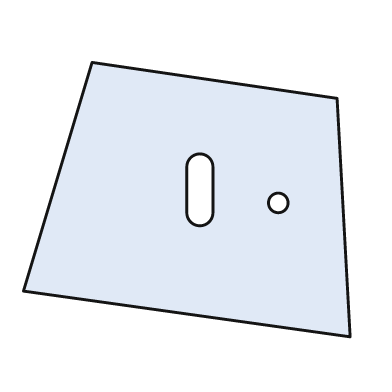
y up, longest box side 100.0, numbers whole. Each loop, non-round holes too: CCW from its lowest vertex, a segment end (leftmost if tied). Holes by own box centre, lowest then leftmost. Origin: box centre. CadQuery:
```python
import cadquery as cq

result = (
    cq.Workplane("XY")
    .moveTo(50.0, -42.0)
    .lineTo(46.0, 31.0)
    .lineTo(-29.0, 42.0)
    .lineTo(-50.0, -28.0)
    .close()
    .moveTo(28.0, -1.0)
    .circle(3.0)
    .moveTo(0.0, -4.0)
    .threePointArc((4.0, -8.0), (8.0, -4.0))
    .lineTo(8.0, 10.0)
    .threePointArc((4.0, 14.0), (0.0, 10.0))
    .close()
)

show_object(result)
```